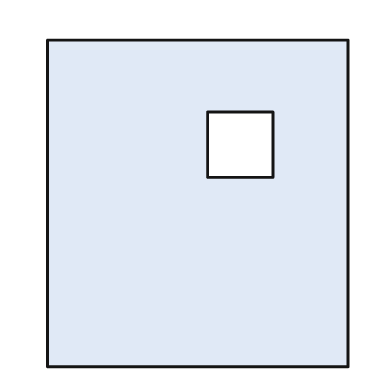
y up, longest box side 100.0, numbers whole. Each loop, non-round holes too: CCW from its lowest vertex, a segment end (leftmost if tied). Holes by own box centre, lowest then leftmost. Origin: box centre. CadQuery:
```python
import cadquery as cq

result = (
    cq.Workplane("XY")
    .moveTo(-46.0, -50.0)
    .lineTo(46.0, -50.0)
    .lineTo(46.0, 50.0)
    .lineTo(-46.0, 50.0)
    .close()
    .moveTo(3.0, 8.0)
    .lineTo(23.0, 8.0)
    .lineTo(23.0, 28.0)
    .lineTo(3.0, 28.0)
    .close()
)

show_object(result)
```